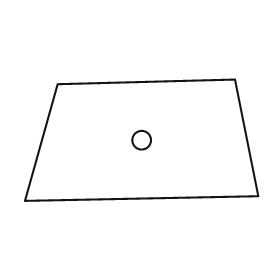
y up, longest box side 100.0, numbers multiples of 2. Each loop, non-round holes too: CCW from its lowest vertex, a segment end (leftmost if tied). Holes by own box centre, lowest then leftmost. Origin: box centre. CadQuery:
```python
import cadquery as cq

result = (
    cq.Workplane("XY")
    .moveTo(-50.0, -26.0)
    .lineTo(50.0, -24.0)
    .lineTo(40.0, 26.0)
    .lineTo(-36.0, 24.0)
    .close()
    .moveTo(0.0, 0.0)
    .circle(4.0)
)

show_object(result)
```